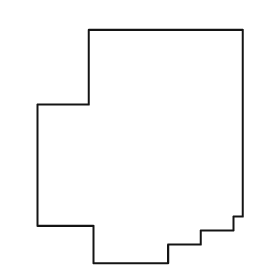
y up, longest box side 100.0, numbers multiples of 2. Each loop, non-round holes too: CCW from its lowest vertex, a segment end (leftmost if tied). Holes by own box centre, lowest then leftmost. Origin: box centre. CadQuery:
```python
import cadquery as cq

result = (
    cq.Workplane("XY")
    .moveTo(-20.0, -50.0)
    .lineTo(12.0, -50.0)
    .lineTo(12.0, -42.0)
    .lineTo(26.0, -42.0)
    .lineTo(26.0, -36.0)
    .lineTo(40.0, -36.0)
    .lineTo(40.0, -30.0)
    .lineTo(44.0, -30.0)
    .lineTo(44.0, 50.0)
    .lineTo(-22.0, 50.0)
    .lineTo(-22.0, 18.0)
    .lineTo(-44.0, 18.0)
    .lineTo(-44.0, -34.0)
    .lineTo(-20.0, -34.0)
    .close()
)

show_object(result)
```